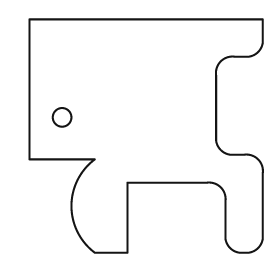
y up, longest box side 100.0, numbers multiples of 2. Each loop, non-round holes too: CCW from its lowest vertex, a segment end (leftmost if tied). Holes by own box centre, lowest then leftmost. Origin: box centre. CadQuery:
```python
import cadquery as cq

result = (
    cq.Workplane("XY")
    .moveTo(-22.0, -50.0)
    .lineTo(-8.0, -50.0)
    .lineTo(-8.0, -20.0)
    .lineTo(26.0, -20.0)
    .threePointArc((32.0, -22.0), (34.0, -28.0))
    .lineTo(34.0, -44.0)
    .threePointArc((36.0, -48.0), (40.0, -50.0))
    .lineTo(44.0, -50.0)
    .threePointArc((48.0, -48.0), (50.0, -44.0))
    .lineTo(50.0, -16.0)
    .threePointArc((48.0, -10.0), (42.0, -8.0))
    .lineTo(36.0, -8.0)
    .threePointArc((32.0, -6.0), (30.0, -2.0))
    .lineTo(30.0, 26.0)
    .threePointArc((32.0, 32.0), (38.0, 34.0))
    .lineTo(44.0, 34.0)
    .threePointArc((48.0, 36.0), (50.0, 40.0))
    .lineTo(50.0, 50.0)
    .lineTo(-50.0, 50.0)
    .lineTo(-50.0, -10.0)
    .lineTo(-22.0, -10.0)
    .threePointArc((-32.0, -30.0), (-22.0, -50.0))
    .close()
    .moveTo(-36.0, 8.0)
    .circle(4.0)
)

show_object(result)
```